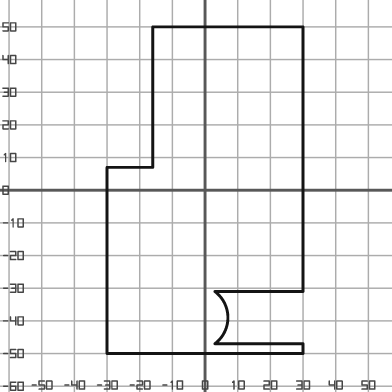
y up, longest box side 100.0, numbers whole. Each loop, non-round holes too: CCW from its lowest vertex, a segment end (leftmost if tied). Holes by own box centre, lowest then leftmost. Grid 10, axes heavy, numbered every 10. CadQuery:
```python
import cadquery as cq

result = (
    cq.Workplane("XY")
    .moveTo(-30.0, -50.0)
    .lineTo(30.0, -50.0)
    .lineTo(30.0, -47.0)
    .lineTo(3.0, -47.0)
    .threePointArc((7.0, -39.0), (3.0, -31.0))
    .lineTo(30.0, -31.0)
    .lineTo(30.0, 50.0)
    .lineTo(-16.0, 50.0)
    .lineTo(-16.0, 7.0)
    .lineTo(-30.0, 7.0)
    .close()
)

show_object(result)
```